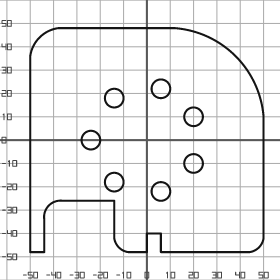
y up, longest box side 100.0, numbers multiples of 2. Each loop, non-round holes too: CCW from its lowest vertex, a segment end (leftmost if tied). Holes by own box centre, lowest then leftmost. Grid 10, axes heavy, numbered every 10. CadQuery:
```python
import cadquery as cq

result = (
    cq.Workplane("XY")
    .moveTo(-50.0, -48.0)
    .lineTo(-44.0, -48.0)
    .lineTo(-44.0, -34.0)
    .threePointArc((-42.0, -28.0), (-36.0, -26.0))
    .lineTo(-14.0, -26.0)
    .lineTo(-14.0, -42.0)
    .threePointArc((-12.0, -46.0), (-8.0, -48.0))
    .lineTo(0.0, -48.0)
    .lineTo(0.0, -40.0)
    .lineTo(6.0, -40.0)
    .lineTo(6.0, -48.0)
    .lineTo(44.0, -48.0)
    .threePointArc((48.0, -46.0), (50.0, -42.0))
    .lineTo(50.0, 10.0)
    .threePointArc((38.0, 36.0), (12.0, 48.0))
    .lineTo(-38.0, 48.0)
    .threePointArc((-46.0, 44.0), (-50.0, 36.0))
    .close()
    .moveTo(6.0, -22.0)
    .circle(4.0)
    .moveTo(-14.0, -18.0)
    .circle(4.0)
    .moveTo(20.0, -10.0)
    .circle(4.0)
    .moveTo(-24.0, 0.0)
    .circle(4.0)
    .moveTo(20.0, 10.0)
    .circle(4.0)
    .moveTo(-14.0, 18.0)
    .circle(4.0)
    .moveTo(6.0, 22.0)
    .circle(4.0)
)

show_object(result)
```